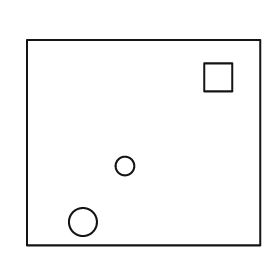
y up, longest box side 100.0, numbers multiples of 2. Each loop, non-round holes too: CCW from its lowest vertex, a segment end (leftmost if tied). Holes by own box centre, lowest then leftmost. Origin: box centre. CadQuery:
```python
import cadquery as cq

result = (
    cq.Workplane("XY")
    .moveTo(-50.0, -44.0)
    .lineTo(50.0, -44.0)
    .lineTo(50.0, 44.0)
    .lineTo(-50.0, 44.0)
    .close()
    .moveTo(-26.0, -34.0)
    .circle(6.0)
    .moveTo(-8.0, -10.0)
    .circle(4.0)
    .moveTo(26.0, 22.0)
    .lineTo(38.0, 22.0)
    .lineTo(38.0, 34.0)
    .lineTo(26.0, 34.0)
    .close()
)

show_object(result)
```